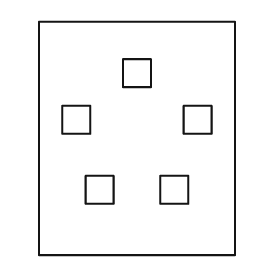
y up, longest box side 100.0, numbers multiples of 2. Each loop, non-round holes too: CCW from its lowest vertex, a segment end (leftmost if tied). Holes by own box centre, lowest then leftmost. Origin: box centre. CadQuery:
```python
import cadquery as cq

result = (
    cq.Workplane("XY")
    .moveTo(-42.0, -50.0)
    .lineTo(42.0, -50.0)
    .lineTo(42.0, 50.0)
    .lineTo(-42.0, 50.0)
    .close()
    .moveTo(-22.0, -28.0)
    .lineTo(-10.0, -28.0)
    .lineTo(-10.0, -16.0)
    .lineTo(-22.0, -16.0)
    .close()
    .moveTo(10.0, -28.0)
    .lineTo(22.0, -28.0)
    .lineTo(22.0, -16.0)
    .lineTo(10.0, -16.0)
    .close()
    .moveTo(-32.0, 2.0)
    .lineTo(-20.0, 2.0)
    .lineTo(-20.0, 14.0)
    .lineTo(-32.0, 14.0)
    .close()
    .moveTo(20.0, 2.0)
    .lineTo(32.0, 2.0)
    .lineTo(32.0, 14.0)
    .lineTo(20.0, 14.0)
    .close()
    .moveTo(-6.0, 22.0)
    .lineTo(6.0, 22.0)
    .lineTo(6.0, 34.0)
    .lineTo(-6.0, 34.0)
    .close()
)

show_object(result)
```